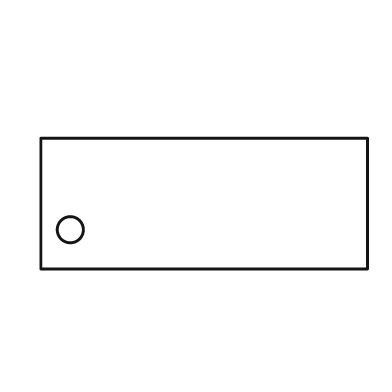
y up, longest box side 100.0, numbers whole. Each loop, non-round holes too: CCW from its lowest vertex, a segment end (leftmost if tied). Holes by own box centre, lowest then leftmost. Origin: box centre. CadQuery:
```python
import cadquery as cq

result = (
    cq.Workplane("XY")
    .moveTo(-50.0, -20.0)
    .lineTo(50.0, -20.0)
    .lineTo(50.0, 20.0)
    .lineTo(-50.0, 20.0)
    .close()
    .moveTo(-41.0, -8.0)
    .circle(4.0)
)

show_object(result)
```